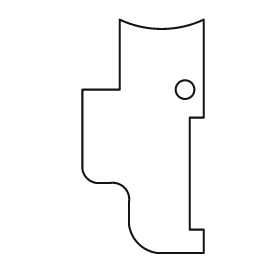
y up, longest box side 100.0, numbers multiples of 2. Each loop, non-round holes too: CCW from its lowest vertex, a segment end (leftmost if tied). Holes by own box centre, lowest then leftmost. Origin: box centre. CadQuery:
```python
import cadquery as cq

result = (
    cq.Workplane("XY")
    .moveTo(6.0, -50.0)
    .lineTo(26.0, -50.0)
    .lineTo(26.0, -40.0)
    .lineTo(20.0, -40.0)
    .lineTo(20.0, 8.0)
    .lineTo(26.0, 8.0)
    .lineTo(26.0, 50.0)
    .threePointArc((8.0, 46.0), (-10.0, 50.0))
    .lineTo(-10.0, 20.0)
    .lineTo(-26.0, 20.0)
    .lineTo(-26.0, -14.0)
    .threePointArc((-24.0, -18.0), (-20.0, -20.0))
    .lineTo(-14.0, -20.0)
    .threePointArc((-8.0, -22.0), (-6.0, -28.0))
    .lineTo(-6.0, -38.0)
    .threePointArc((-2.0, -46.0), (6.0, -50.0))
    .close()
    .moveTo(18.0, 20.0)
    .circle(4.0)
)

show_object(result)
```